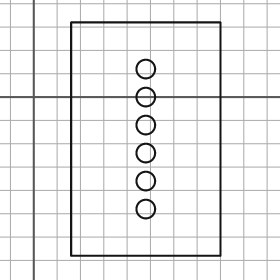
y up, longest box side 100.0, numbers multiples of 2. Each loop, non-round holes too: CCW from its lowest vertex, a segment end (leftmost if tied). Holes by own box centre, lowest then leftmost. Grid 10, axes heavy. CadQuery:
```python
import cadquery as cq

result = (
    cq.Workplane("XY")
    .moveTo(16.0, -68.0)
    .lineTo(80.0, -68.0)
    .lineTo(80.0, 32.0)
    .lineTo(16.0, 32.0)
    .close()
    .moveTo(48.0, -48.0)
    .circle(4.0)
    .moveTo(48.0, -36.0)
    .circle(4.0)
    .moveTo(48.0, -24.0)
    .circle(4.0)
    .moveTo(48.0, -12.0)
    .circle(4.0)
    .moveTo(48.0, 0.0)
    .circle(4.0)
    .moveTo(48.0, 12.0)
    .circle(4.0)
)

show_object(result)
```